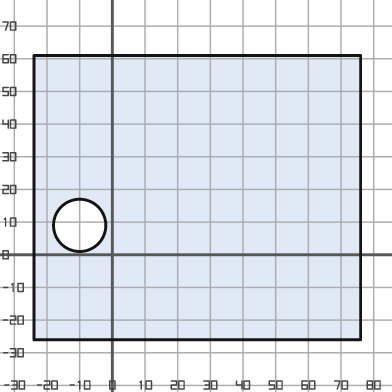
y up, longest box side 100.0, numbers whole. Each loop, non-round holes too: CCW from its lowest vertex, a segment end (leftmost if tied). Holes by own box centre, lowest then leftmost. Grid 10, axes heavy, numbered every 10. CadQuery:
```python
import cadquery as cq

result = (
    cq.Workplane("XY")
    .moveTo(-24.0, -26.0)
    .lineTo(76.0, -26.0)
    .lineTo(76.0, 61.0)
    .lineTo(-24.0, 61.0)
    .close()
    .moveTo(-10.0, 9.0)
    .circle(8.0)
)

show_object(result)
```